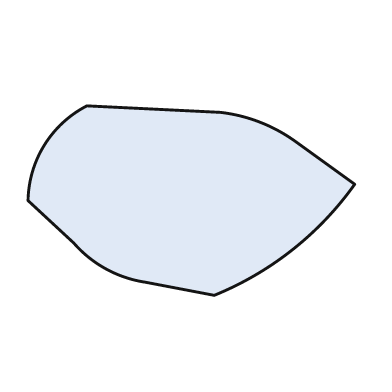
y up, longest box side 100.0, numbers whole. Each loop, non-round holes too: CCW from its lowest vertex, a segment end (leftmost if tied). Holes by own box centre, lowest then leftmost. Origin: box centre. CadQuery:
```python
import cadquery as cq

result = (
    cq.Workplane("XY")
    .moveTo(7.0, -29.0)
    .threePointArc((31.0, -15.0), (50.0, 5.0))
    .lineTo(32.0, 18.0)
    .threePointArc((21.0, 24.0), (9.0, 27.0))
    .lineTo(-32.0, 29.0)
    .threePointArc((-45.0, 17.0), (-50.0, 0.0))
    .lineTo(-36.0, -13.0)
    .threePointArc((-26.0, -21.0), (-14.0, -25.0))
    .close()
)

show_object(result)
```